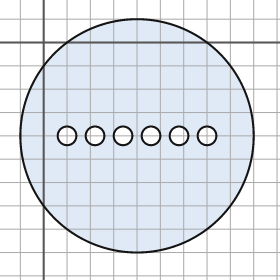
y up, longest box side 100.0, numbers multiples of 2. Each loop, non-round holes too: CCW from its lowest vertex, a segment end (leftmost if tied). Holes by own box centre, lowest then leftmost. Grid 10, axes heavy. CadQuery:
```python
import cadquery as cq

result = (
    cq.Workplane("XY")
    .moveTo(40.0, -40.0)
    .circle(50.0)
    .moveTo(10.0, -40.0)
    .circle(4.0)
    .moveTo(22.0, -40.0)
    .circle(4.0)
    .moveTo(34.0, -40.0)
    .circle(4.0)
    .moveTo(46.0, -40.0)
    .circle(4.0)
    .moveTo(58.0, -40.0)
    .circle(4.0)
    .moveTo(70.0, -40.0)
    .circle(4.0)
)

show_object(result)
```